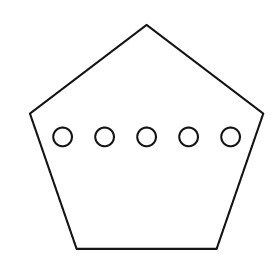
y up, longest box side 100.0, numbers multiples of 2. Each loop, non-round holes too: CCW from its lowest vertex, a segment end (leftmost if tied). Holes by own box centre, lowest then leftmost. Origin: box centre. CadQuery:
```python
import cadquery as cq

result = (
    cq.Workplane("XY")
    .moveTo(-30.0, -48.0)
    .lineTo(30.0, -48.0)
    .lineTo(50.0, 10.0)
    .lineTo(0.0, 48.0)
    .lineTo(-50.0, 10.0)
    .close()
    .moveTo(-36.0, 0.0)
    .circle(4.0)
    .moveTo(-18.0, 0.0)
    .circle(4.0)
    .moveTo(0.0, 0.0)
    .circle(4.0)
    .moveTo(18.0, 0.0)
    .circle(4.0)
    .moveTo(36.0, 0.0)
    .circle(4.0)
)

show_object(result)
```